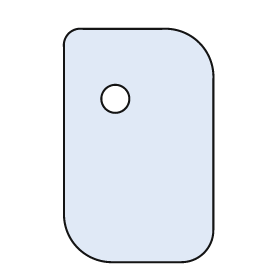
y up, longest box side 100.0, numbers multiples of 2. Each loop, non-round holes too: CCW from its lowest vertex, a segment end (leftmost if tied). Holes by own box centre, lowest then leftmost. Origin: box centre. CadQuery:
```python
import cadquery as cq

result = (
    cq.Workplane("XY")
    .moveTo(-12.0, -50.0)
    .lineTo(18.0, -50.0)
    .threePointArc((28.0, -46.0), (32.0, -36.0))
    .lineTo(32.0, 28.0)
    .threePointArc((26.0, 44.0), (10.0, 50.0))
    .lineTo(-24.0, 50.0)
    .threePointArc((-30.0, 48.0), (-32.0, 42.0))
    .lineTo(-32.0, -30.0)
    .threePointArc((-26.0, -44.0), (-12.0, -50.0))
    .close()
    .moveTo(-10.0, 20.0)
    .circle(6.0)
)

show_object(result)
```